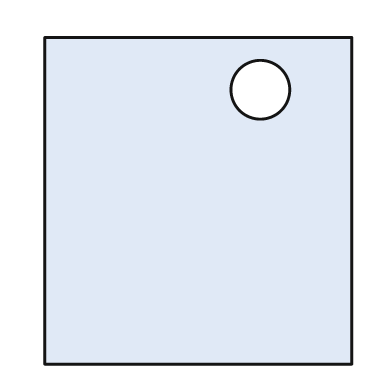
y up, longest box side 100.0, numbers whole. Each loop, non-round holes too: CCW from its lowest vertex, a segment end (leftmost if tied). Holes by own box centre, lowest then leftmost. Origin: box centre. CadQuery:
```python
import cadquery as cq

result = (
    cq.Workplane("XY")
    .moveTo(-47.0, -50.0)
    .lineTo(47.0, -50.0)
    .lineTo(47.0, 50.0)
    .lineTo(-47.0, 50.0)
    .close()
    .moveTo(19.0, 34.0)
    .circle(9.0)
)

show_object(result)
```